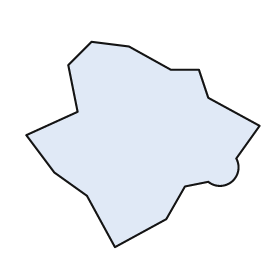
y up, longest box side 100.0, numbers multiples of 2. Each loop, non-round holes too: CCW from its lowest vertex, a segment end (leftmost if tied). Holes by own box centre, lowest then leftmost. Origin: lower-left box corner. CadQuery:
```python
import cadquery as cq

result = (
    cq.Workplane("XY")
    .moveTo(38.0, 0.0)
    .lineTo(60.0, 12.0)
    .lineTo(68.0, 26.0)
    .lineTo(78.0, 28.0)
    .threePointArc((88.0, 28.0), (90.0, 38.0))
    .lineTo(100.0, 52.0)
    .lineTo(78.0, 64.0)
    .lineTo(74.0, 76.0)
    .lineTo(62.0, 76.0)
    .lineTo(44.0, 86.0)
    .lineTo(28.0, 88.0)
    .lineTo(18.0, 78.0)
    .lineTo(22.0, 58.0)
    .lineTo(0.0, 48.0)
    .lineTo(12.0, 32.0)
    .lineTo(26.0, 22.0)
    .close()
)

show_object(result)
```